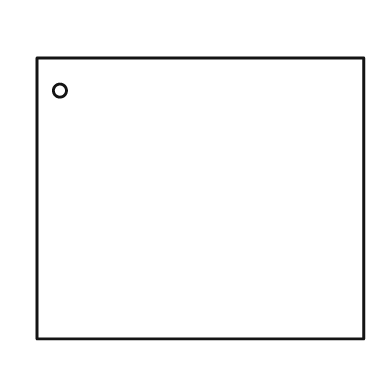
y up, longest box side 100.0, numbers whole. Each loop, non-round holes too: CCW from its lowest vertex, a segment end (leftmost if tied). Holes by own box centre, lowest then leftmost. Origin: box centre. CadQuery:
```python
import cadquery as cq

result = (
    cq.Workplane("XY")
    .moveTo(-50.0, -43.0)
    .lineTo(50.0, -43.0)
    .lineTo(50.0, 43.0)
    .lineTo(-50.0, 43.0)
    .close()
    .moveTo(-43.0, 33.0)
    .circle(2.0)
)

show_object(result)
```